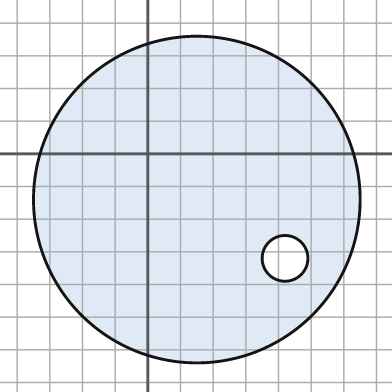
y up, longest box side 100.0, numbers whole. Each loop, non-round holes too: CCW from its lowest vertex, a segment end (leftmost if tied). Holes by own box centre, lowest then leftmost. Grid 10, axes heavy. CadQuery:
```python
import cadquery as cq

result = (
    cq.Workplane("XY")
    .moveTo(15.0, -14.0)
    .circle(50.0)
    .moveTo(42.0, -32.0)
    .circle(7.0)
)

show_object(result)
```